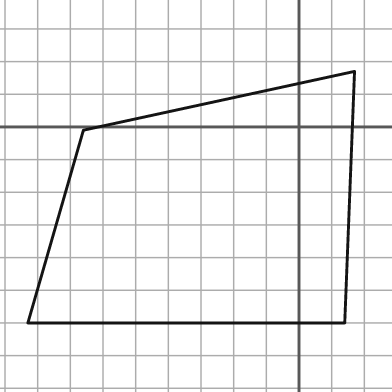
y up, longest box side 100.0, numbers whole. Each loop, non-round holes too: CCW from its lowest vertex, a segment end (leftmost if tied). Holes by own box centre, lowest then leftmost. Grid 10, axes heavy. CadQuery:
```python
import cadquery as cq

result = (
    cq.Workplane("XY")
    .moveTo(-83.0, -60.0)
    .lineTo(14.0, -60.0)
    .lineTo(17.0, 17.0)
    .lineTo(-66.0, -1.0)
    .close()
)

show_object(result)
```